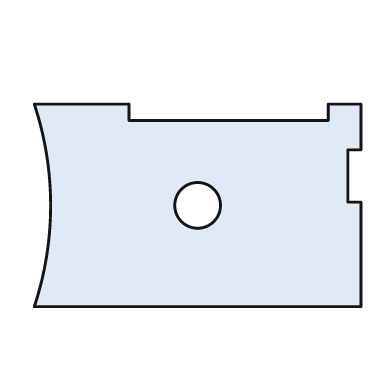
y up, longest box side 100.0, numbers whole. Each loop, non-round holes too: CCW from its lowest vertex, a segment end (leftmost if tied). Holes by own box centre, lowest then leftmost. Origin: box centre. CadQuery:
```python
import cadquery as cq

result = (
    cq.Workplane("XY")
    .moveTo(-50.0, -31.0)
    .lineTo(50.0, -31.0)
    .lineTo(50.0, 1.0)
    .lineTo(46.0, 1.0)
    .lineTo(46.0, 17.0)
    .lineTo(50.0, 17.0)
    .lineTo(50.0, 31.0)
    .lineTo(40.0, 31.0)
    .lineTo(40.0, 26.0)
    .lineTo(-21.0, 26.0)
    .lineTo(-21.0, 31.0)
    .lineTo(-50.0, 31.0)
    .threePointArc((-45.0, 0.0), (-50.0, -31.0))
    .close()
    .moveTo(0.0, 0.0)
    .circle(7.0)
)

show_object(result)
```